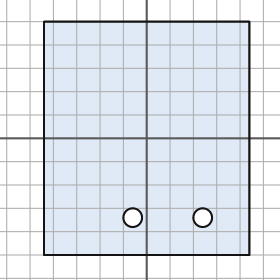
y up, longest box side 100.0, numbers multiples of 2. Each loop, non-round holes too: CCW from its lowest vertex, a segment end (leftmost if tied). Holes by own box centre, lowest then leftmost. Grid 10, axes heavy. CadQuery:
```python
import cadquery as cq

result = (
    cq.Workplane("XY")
    .moveTo(-44.0, -50.0)
    .lineTo(44.0, -50.0)
    .lineTo(44.0, 50.0)
    .lineTo(-44.0, 50.0)
    .close()
    .moveTo(-6.0, -34.0)
    .circle(4.0)
    .moveTo(24.0, -34.0)
    .circle(4.0)
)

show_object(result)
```